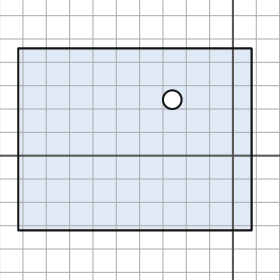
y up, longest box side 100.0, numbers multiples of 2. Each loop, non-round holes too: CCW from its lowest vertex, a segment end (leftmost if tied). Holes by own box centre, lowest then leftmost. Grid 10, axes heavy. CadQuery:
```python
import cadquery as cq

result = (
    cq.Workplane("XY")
    .moveTo(-92.0, -32.0)
    .lineTo(8.0, -32.0)
    .lineTo(8.0, 46.0)
    .lineTo(-92.0, 46.0)
    .close()
    .moveTo(-26.0, 24.0)
    .circle(4.0)
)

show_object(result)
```